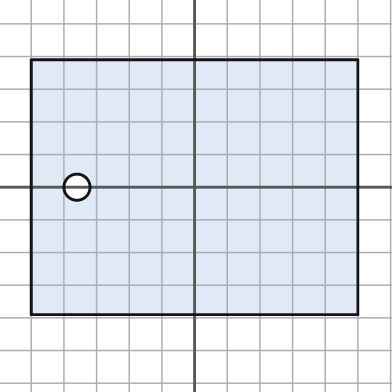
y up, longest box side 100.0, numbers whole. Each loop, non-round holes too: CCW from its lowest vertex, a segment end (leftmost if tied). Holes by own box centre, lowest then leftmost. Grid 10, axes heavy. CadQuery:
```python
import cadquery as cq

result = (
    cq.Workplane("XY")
    .moveTo(-50.0, -39.0)
    .lineTo(50.0, -39.0)
    .lineTo(50.0, 39.0)
    .lineTo(-50.0, 39.0)
    .close()
    .moveTo(-36.0, 0.0)
    .circle(4.0)
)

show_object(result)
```